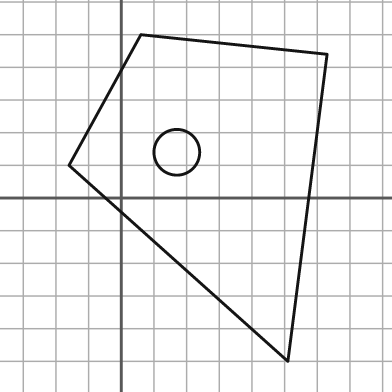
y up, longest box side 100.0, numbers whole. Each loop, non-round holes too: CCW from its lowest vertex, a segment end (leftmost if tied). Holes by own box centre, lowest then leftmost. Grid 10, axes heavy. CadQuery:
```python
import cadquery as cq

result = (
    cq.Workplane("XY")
    .moveTo(51.0, -50.0)
    .lineTo(63.0, 44.0)
    .lineTo(6.0, 50.0)
    .lineTo(-16.0, 10.0)
    .close()
    .moveTo(17.0, 14.0)
    .circle(7.0)
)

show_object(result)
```